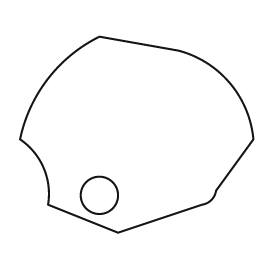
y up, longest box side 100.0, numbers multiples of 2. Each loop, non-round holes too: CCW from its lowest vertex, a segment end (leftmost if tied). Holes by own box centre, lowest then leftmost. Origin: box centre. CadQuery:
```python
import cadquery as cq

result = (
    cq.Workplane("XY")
    .moveTo(-8.0, -42.0)
    .lineTo(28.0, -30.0)
    .threePointArc((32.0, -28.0), (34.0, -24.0))
    .lineTo(50.0, -2.0)
    .threePointArc((40.0, 22.0), (18.0, 36.0))
    .lineTo(-16.0, 42.0)
    .threePointArc((-38.0, 24.0), (-50.0, -2.0))
    .threePointArc((-40.0, -14.0), (-38.0, -30.0))
    .close()
    .moveTo(-16.0, -26.0)
    .circle(8.0)
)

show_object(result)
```